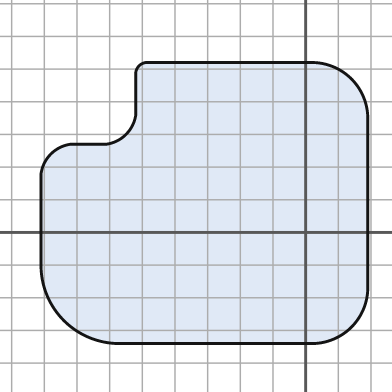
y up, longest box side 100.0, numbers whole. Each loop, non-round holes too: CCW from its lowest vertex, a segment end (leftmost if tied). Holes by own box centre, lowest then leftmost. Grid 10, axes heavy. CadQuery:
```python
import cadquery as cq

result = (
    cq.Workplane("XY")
    .moveTo(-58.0, -34.0)
    .lineTo(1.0, -34.0)
    .threePointArc((14.0, -29.0), (19.0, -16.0))
    .lineTo(19.0, 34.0)
    .threePointArc((14.0, 47.0), (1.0, 52.0))
    .lineTo(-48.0, 52.0)
    .threePointArc((-51.0, 51.0), (-52.0, 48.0))
    .lineTo(-52.0, 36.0)
    .threePointArc((-55.0, 30.0), (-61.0, 27.0))
    .lineTo(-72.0, 27.0)
    .threePointArc((-78.0, 24.0), (-81.0, 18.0))
    .lineTo(-81.0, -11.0)
    .threePointArc((-74.0, -27.0), (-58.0, -34.0))
    .close()
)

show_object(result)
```